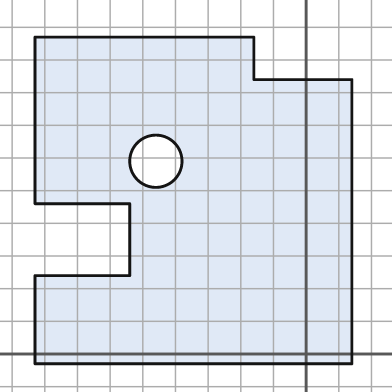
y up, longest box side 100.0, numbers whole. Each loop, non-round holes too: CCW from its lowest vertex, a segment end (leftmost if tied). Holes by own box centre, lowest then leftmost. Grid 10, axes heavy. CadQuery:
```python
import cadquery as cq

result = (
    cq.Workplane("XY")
    .moveTo(-83.0, -3.0)
    .lineTo(14.0, -3.0)
    .lineTo(14.0, 84.0)
    .lineTo(-16.0, 84.0)
    .lineTo(-16.0, 97.0)
    .lineTo(-83.0, 97.0)
    .lineTo(-83.0, 46.0)
    .lineTo(-54.0, 46.0)
    .lineTo(-54.0, 24.0)
    .lineTo(-83.0, 24.0)
    .close()
    .moveTo(-46.0, 59.0)
    .circle(8.0)
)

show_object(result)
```